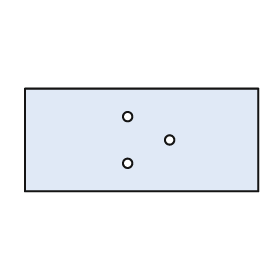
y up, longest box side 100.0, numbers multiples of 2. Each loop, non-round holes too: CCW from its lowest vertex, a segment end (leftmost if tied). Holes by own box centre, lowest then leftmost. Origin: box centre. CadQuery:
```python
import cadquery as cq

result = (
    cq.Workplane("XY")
    .moveTo(-50.0, -22.0)
    .lineTo(50.0, -22.0)
    .lineTo(50.0, 22.0)
    .lineTo(-50.0, 22.0)
    .close()
    .moveTo(-6.0, -10.0)
    .circle(2.0)
    .moveTo(12.0, 0.0)
    .circle(2.0)
    .moveTo(-6.0, 10.0)
    .circle(2.0)
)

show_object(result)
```